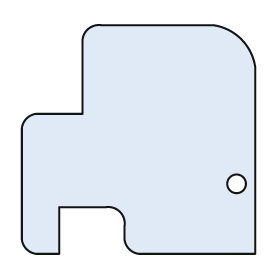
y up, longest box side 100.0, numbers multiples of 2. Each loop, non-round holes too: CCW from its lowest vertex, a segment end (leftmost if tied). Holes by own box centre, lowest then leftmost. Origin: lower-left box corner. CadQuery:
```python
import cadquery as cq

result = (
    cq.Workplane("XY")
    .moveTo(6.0, 0.0)
    .lineTo(16.0, 0.0)
    .lineTo(16.0, 20.0)
    .lineTo(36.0, 20.0)
    .threePointArc((42.0, 18.0), (44.0, 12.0))
    .lineTo(44.0, 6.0)
    .threePointArc((46.0, 2.0), (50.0, 0.0))
    .lineTo(100.0, 0.0)
    .lineTo(100.0, 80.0)
    .threePointArc((94.0, 92.0), (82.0, 98.0))
    .lineTo(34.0, 98.0)
    .threePointArc((28.0, 96.0), (26.0, 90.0))
    .lineTo(26.0, 60.0)
    .lineTo(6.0, 60.0)
    .threePointArc((2.0, 58.0), (0.0, 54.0))
    .lineTo(0.0, 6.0)
    .threePointArc((2.0, 2.0), (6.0, 0.0))
    .close()
    .moveTo(92.0, 30.0)
    .circle(4.0)
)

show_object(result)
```